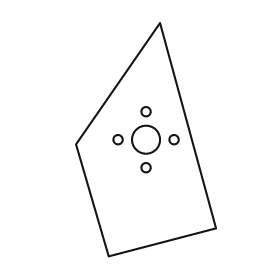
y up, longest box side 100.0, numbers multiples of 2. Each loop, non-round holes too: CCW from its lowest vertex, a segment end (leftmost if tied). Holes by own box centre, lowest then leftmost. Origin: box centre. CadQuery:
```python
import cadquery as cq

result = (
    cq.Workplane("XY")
    .moveTo(-16.0, -50.0)
    .lineTo(30.0, -38.0)
    .lineTo(6.0, 50.0)
    .lineTo(-30.0, -2.0)
    .close()
    .moveTo(0.0, -12.0)
    .circle(2.0)
    .moveTo(-12.0, 0.0)
    .circle(2.0)
    .moveTo(0.0, 0.0)
    .circle(6.0)
    .moveTo(12.0, 0.0)
    .circle(2.0)
    .moveTo(0.0, 12.0)
    .circle(2.0)
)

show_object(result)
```